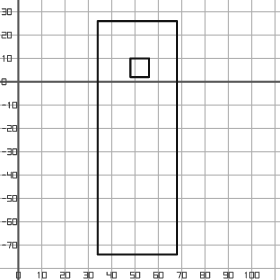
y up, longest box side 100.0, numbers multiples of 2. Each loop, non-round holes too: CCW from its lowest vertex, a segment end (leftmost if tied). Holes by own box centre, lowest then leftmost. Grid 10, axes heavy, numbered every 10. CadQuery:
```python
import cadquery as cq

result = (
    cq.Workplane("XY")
    .moveTo(34.0, -74.0)
    .lineTo(68.0, -74.0)
    .lineTo(68.0, 26.0)
    .lineTo(34.0, 26.0)
    .close()
    .moveTo(48.0, 2.0)
    .lineTo(56.0, 2.0)
    .lineTo(56.0, 10.0)
    .lineTo(48.0, 10.0)
    .close()
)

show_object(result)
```